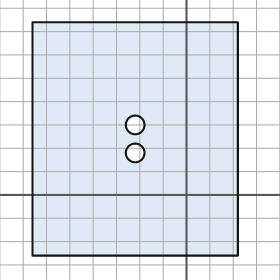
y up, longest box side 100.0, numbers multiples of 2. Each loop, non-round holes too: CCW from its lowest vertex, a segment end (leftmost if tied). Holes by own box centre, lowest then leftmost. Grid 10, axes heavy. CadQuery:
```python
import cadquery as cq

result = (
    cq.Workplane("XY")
    .moveTo(-66.0, -26.0)
    .lineTo(22.0, -26.0)
    .lineTo(22.0, 74.0)
    .lineTo(-66.0, 74.0)
    .close()
    .moveTo(-22.0, 18.0)
    .circle(4.0)
    .moveTo(-22.0, 30.0)
    .circle(4.0)
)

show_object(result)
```